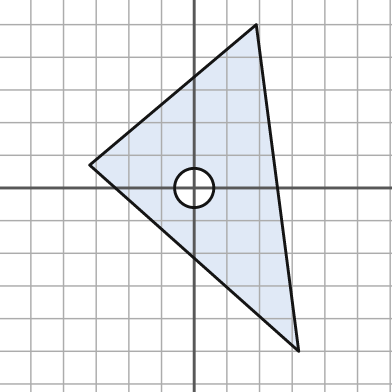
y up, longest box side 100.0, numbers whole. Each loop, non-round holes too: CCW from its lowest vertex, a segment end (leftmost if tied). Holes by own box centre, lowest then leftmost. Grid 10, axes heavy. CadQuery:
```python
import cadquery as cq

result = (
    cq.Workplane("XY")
    .moveTo(32.0, -50.0)
    .lineTo(19.0, 50.0)
    .lineTo(-32.0, 7.0)
    .close()
    .moveTo(0.0, 0.0)
    .circle(6.0)
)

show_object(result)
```